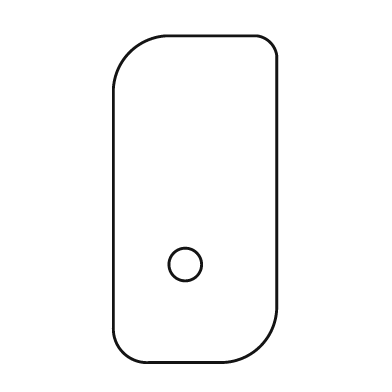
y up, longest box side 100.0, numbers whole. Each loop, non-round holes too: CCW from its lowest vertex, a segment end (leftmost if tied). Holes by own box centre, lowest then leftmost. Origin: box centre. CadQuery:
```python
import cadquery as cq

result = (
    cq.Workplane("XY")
    .moveTo(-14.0, -50.0)
    .lineTo(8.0, -50.0)
    .threePointArc((20.0, -45.0), (25.0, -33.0))
    .lineTo(25.0, 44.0)
    .threePointArc((23.0, 48.0), (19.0, 50.0))
    .lineTo(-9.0, 50.0)
    .threePointArc((-20.0, 45.0), (-25.0, 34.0))
    .lineTo(-25.0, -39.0)
    .threePointArc((-22.0, -47.0), (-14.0, -50.0))
    .close()
    .moveTo(-3.0, -20.0)
    .circle(5.0)
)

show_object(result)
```